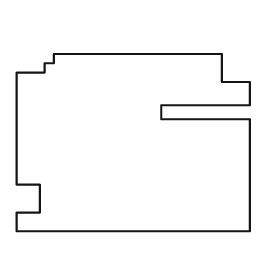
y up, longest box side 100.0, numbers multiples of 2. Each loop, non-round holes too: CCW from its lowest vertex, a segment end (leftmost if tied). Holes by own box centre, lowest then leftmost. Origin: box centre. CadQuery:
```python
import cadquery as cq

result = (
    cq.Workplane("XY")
    .moveTo(-50.0, -38.0)
    .lineTo(50.0, -38.0)
    .lineTo(50.0, 10.0)
    .lineTo(12.0, 10.0)
    .lineTo(12.0, 16.0)
    .lineTo(50.0, 16.0)
    .lineTo(50.0, 26.0)
    .lineTo(38.0, 26.0)
    .lineTo(38.0, 38.0)
    .lineTo(-34.0, 38.0)
    .lineTo(-34.0, 34.0)
    .lineTo(-38.0, 34.0)
    .lineTo(-38.0, 30.0)
    .lineTo(-50.0, 30.0)
    .lineTo(-50.0, -18.0)
    .lineTo(-40.0, -18.0)
    .lineTo(-40.0, -30.0)
    .lineTo(-50.0, -30.0)
    .close()
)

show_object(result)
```